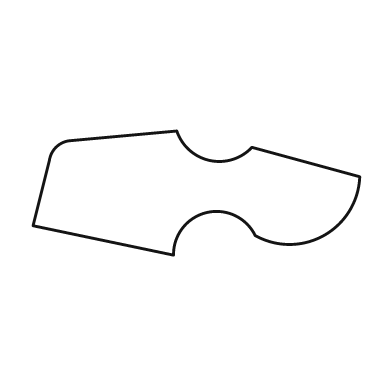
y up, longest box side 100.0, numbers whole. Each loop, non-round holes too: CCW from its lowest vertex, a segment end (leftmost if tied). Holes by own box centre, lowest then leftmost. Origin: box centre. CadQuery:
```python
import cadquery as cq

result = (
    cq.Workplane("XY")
    .moveTo(-7.0, -19.0)
    .threePointArc((3.0, -6.0), (18.0, -13.0))
    .threePointArc((39.0, -13.0), (50.0, 5.0))
    .lineTo(17.0, 14.0)
    .threePointArc((4.0, 10.0), (-6.0, 19.0))
    .lineTo(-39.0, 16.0)
    .threePointArc((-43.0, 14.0), (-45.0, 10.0))
    .lineTo(-50.0, -10.0)
    .close()
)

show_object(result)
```